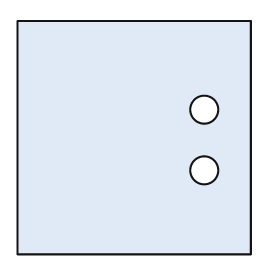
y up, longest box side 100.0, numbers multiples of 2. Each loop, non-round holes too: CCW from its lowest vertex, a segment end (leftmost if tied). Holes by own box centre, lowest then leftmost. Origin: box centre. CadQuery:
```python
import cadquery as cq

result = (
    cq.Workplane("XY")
    .moveTo(-50.0, -50.0)
    .lineTo(50.0, -50.0)
    .lineTo(50.0, 50.0)
    .lineTo(-50.0, 50.0)
    .close()
    .moveTo(30.0, -14.0)
    .circle(6.0)
    .moveTo(30.0, 12.0)
    .circle(6.0)
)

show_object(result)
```